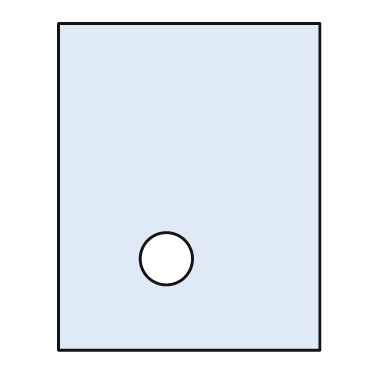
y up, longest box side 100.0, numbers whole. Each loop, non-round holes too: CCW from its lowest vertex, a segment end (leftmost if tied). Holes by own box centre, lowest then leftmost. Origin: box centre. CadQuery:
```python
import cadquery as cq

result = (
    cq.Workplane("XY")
    .moveTo(-40.0, -50.0)
    .lineTo(40.0, -50.0)
    .lineTo(40.0, 50.0)
    .lineTo(-40.0, 50.0)
    .close()
    .moveTo(-7.0, -22.0)
    .circle(8.0)
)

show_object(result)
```